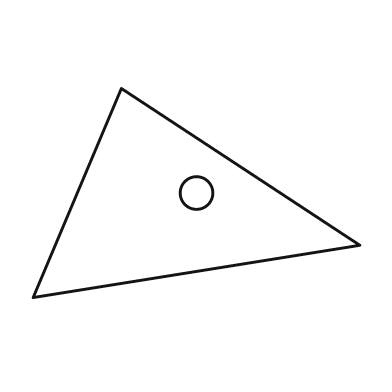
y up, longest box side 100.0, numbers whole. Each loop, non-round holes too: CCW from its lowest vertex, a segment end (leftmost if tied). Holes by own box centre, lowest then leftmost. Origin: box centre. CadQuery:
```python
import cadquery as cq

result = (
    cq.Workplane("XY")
    .moveTo(-50.0, -32.0)
    .lineTo(50.0, -16.0)
    .lineTo(-23.0, 32.0)
    .close()
    .moveTo(0.0, 0.0)
    .circle(5.0)
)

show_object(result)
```